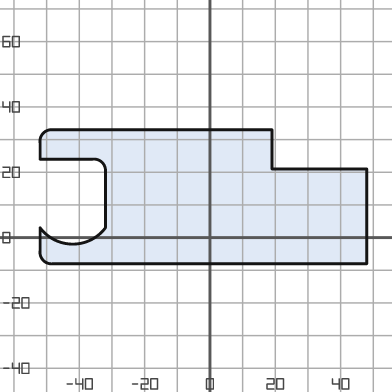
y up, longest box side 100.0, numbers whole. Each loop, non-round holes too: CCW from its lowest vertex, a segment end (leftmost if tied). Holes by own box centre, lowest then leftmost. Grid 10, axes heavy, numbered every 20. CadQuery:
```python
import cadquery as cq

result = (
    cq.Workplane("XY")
    .moveTo(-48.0, -8.0)
    .lineTo(48.0, -8.0)
    .lineTo(48.0, 21.0)
    .lineTo(19.0, 21.0)
    .lineTo(19.0, 33.0)
    .lineTo(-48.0, 33.0)
    .threePointArc((-51.0, 32.0), (-52.0, 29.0))
    .lineTo(-52.0, 24.0)
    .lineTo(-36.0, 24.0)
    .threePointArc((-33.0, 23.0), (-32.0, 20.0))
    .lineTo(-32.0, 3.0)
    .threePointArc((-42.0, -2.0), (-52.0, 3.0))
    .lineTo(-52.0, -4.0)
    .threePointArc((-51.0, -7.0), (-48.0, -8.0))
    .close()
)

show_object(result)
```